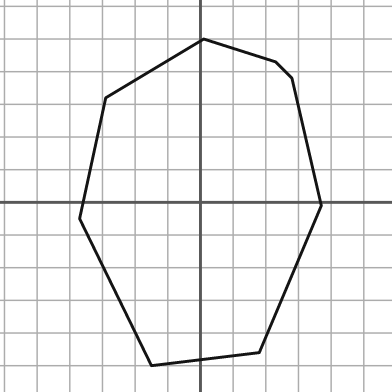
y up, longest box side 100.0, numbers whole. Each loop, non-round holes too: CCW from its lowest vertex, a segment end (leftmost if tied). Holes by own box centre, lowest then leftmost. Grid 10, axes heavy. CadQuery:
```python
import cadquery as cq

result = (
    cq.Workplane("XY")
    .moveTo(-15.0, -50.0)
    .lineTo(18.0, -46.0)
    .lineTo(37.0, -1.0)
    .lineTo(28.0, 38.0)
    .lineTo(23.0, 43.0)
    .lineTo(1.0, 50.0)
    .lineTo(-29.0, 32.0)
    .lineTo(-37.0, -5.0)
    .close()
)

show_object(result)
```